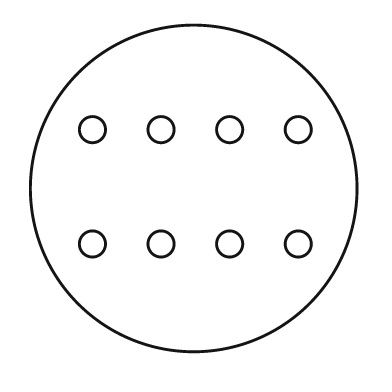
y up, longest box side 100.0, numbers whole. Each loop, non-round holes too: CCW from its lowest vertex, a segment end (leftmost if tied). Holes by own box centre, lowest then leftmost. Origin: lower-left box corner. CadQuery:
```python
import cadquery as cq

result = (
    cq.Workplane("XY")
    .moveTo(50.0, 50.0)
    .circle(50.0)
    .moveTo(19.0, 33.0)
    .circle(4.0)
    .moveTo(40.0, 33.0)
    .circle(4.0)
    .moveTo(61.0, 33.0)
    .circle(4.0)
    .moveTo(82.0, 33.0)
    .circle(4.0)
    .moveTo(19.0, 68.0)
    .circle(4.0)
    .moveTo(40.0, 68.0)
    .circle(4.0)
    .moveTo(61.0, 68.0)
    .circle(4.0)
    .moveTo(82.0, 68.0)
    .circle(4.0)
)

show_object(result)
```